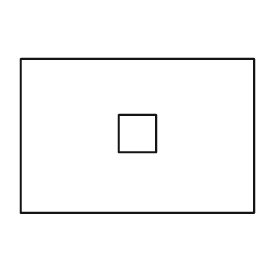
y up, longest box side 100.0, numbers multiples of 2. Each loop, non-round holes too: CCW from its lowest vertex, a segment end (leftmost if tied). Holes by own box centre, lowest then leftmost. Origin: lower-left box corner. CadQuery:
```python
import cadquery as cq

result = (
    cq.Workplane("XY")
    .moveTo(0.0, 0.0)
    .lineTo(100.0, 0.0)
    .lineTo(100.0, 66.0)
    .lineTo(0.0, 66.0)
    .close()
    .moveTo(42.0, 26.0)
    .lineTo(58.0, 26.0)
    .lineTo(58.0, 42.0)
    .lineTo(42.0, 42.0)
    .close()
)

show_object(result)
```